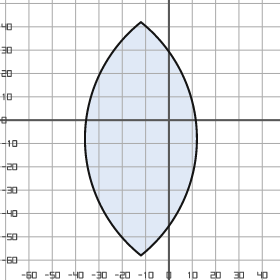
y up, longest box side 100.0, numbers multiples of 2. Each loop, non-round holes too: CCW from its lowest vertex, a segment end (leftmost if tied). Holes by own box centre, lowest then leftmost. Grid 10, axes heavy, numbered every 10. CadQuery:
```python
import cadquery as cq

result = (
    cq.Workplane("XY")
    .moveTo(-12.0, -58.0)
    .threePointArc((12.0, -8.0), (-12.0, 42.0))
    .threePointArc((-36.0, -8.0), (-12.0, -58.0))
    .close()
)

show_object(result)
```